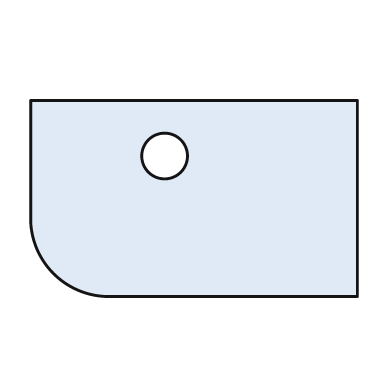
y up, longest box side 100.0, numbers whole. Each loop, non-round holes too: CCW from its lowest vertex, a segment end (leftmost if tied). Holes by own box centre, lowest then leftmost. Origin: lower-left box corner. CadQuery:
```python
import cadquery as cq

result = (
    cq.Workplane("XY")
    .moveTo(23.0, 0.0)
    .lineTo(100.0, 0.0)
    .lineTo(100.0, 60.0)
    .lineTo(0.0, 60.0)
    .lineTo(0.0, 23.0)
    .threePointArc((7.0, 7.0), (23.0, 0.0))
    .close()
    .moveTo(41.0, 43.0)
    .circle(7.0)
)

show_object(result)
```